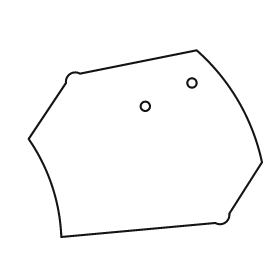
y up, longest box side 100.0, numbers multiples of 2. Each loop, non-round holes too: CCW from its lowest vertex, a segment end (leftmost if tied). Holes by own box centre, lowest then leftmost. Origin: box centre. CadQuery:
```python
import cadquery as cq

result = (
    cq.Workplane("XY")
    .moveTo(-36.0, -40.0)
    .lineTo(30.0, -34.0)
    .threePointArc((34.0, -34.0), (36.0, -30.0))
    .lineTo(50.0, -8.0)
    .threePointArc((40.0, 18.0), (22.0, 40.0))
    .lineTo(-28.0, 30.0)
    .threePointArc((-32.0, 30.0), (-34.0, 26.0))
    .lineTo(-50.0, 2.0)
    .threePointArc((-40.0, -18.0), (-36.0, -40.0))
    .close()
    .moveTo(0.0, 16.0)
    .circle(2.0)
    .moveTo(20.0, 26.0)
    .circle(2.0)
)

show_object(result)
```